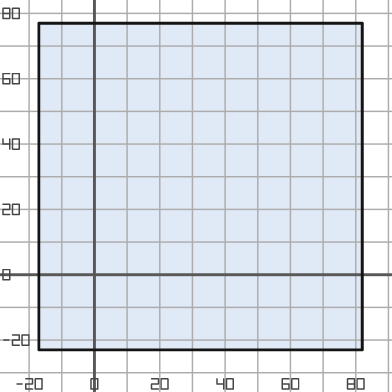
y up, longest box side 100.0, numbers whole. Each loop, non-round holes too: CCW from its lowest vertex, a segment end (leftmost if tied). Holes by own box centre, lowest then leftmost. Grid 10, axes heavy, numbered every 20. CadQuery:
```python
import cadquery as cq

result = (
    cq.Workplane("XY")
    .moveTo(-17.0, -23.0)
    .lineTo(82.0, -23.0)
    .lineTo(82.0, 77.0)
    .lineTo(-17.0, 77.0)
    .close()
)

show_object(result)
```